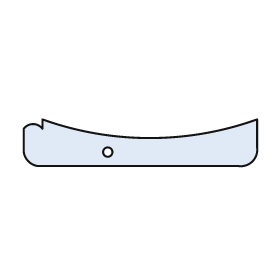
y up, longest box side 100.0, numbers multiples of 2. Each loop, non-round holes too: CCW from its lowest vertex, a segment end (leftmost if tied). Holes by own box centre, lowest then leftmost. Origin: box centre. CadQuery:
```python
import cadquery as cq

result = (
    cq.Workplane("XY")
    .moveTo(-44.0, -10.0)
    .lineTo(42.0, -10.0)
    .threePointArc((48.0, -8.0), (50.0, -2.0))
    .lineTo(50.0, 10.0)
    .threePointArc((4.0, 2.0), (-42.0, 10.0))
    .lineTo(-42.0, 6.0)
    .threePointArc((-46.0, 8.0), (-50.0, 6.0))
    .lineTo(-50.0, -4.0)
    .threePointArc((-48.0, -8.0), (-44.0, -10.0))
    .close()
    .moveTo(-14.0, -4.0)
    .circle(2.0)
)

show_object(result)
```